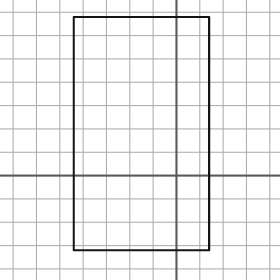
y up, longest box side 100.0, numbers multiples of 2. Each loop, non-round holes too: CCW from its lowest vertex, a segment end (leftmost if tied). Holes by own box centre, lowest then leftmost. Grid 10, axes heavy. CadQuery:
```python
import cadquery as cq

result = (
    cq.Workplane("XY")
    .moveTo(-44.0, -32.0)
    .lineTo(14.0, -32.0)
    .lineTo(14.0, 68.0)
    .lineTo(-44.0, 68.0)
    .close()
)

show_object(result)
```